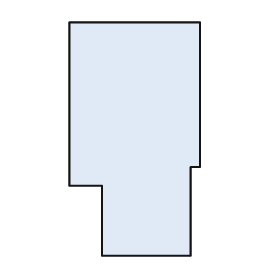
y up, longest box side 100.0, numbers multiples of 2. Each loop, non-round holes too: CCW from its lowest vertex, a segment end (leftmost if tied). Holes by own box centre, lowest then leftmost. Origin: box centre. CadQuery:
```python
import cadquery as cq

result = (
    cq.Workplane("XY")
    .moveTo(-14.0, -50.0)
    .lineTo(24.0, -50.0)
    .lineTo(24.0, -12.0)
    .lineTo(28.0, -12.0)
    .lineTo(28.0, 50.0)
    .lineTo(-28.0, 50.0)
    .lineTo(-28.0, -20.0)
    .lineTo(-14.0, -20.0)
    .close()
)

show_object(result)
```